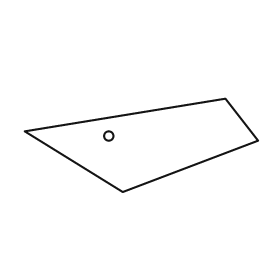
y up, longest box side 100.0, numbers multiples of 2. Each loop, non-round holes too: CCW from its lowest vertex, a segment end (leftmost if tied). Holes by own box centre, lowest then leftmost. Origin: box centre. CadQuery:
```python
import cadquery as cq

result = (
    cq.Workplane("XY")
    .moveTo(-8.0, -20.0)
    .lineTo(50.0, 2.0)
    .lineTo(36.0, 20.0)
    .lineTo(-50.0, 6.0)
    .close()
    .moveTo(-14.0, 4.0)
    .circle(2.0)
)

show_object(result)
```